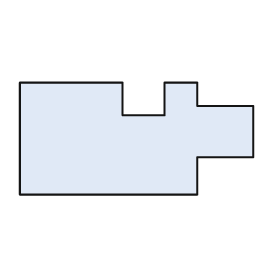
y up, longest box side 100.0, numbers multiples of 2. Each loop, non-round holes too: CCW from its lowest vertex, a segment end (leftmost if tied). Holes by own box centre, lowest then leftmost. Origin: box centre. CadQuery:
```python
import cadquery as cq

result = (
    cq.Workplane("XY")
    .moveTo(-50.0, -24.0)
    .lineTo(26.0, -24.0)
    .lineTo(26.0, -8.0)
    .lineTo(50.0, -8.0)
    .lineTo(50.0, 14.0)
    .lineTo(26.0, 14.0)
    .lineTo(26.0, 24.0)
    .lineTo(12.0, 24.0)
    .lineTo(12.0, 10.0)
    .lineTo(-6.0, 10.0)
    .lineTo(-6.0, 24.0)
    .lineTo(-50.0, 24.0)
    .close()
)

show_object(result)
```